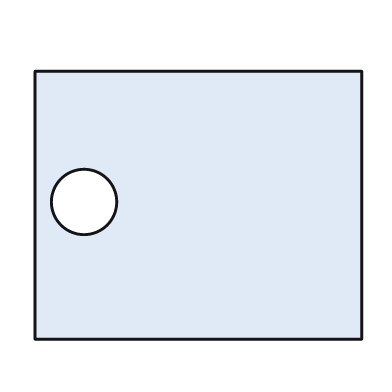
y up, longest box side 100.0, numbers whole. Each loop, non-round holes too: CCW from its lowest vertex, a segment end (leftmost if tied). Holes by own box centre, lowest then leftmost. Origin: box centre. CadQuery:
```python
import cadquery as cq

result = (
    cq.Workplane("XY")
    .moveTo(-50.0, -41.0)
    .lineTo(50.0, -41.0)
    .lineTo(50.0, 41.0)
    .lineTo(-50.0, 41.0)
    .close()
    .moveTo(-35.0, 1.0)
    .circle(10.0)
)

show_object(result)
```